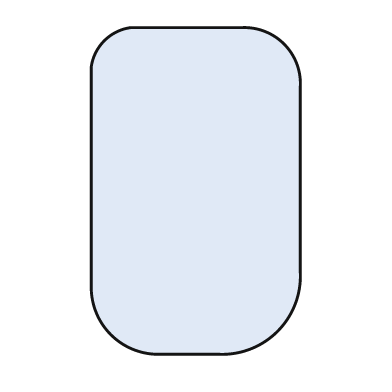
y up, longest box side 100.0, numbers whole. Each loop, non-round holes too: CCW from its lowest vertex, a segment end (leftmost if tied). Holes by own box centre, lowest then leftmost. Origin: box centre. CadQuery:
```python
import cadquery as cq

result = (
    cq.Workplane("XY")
    .moveTo(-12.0, -50.0)
    .lineTo(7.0, -50.0)
    .threePointArc((25.0, -43.0), (32.0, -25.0))
    .lineTo(32.0, 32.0)
    .threePointArc((27.0, 45.0), (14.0, 50.0))
    .lineTo(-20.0, 50.0)
    .threePointArc((-28.0, 46.0), (-32.0, 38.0))
    .lineTo(-32.0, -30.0)
    .threePointArc((-26.0, -44.0), (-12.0, -50.0))
    .close()
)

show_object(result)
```